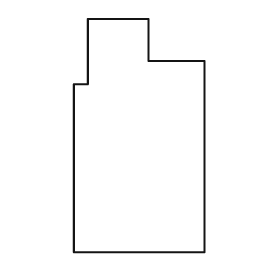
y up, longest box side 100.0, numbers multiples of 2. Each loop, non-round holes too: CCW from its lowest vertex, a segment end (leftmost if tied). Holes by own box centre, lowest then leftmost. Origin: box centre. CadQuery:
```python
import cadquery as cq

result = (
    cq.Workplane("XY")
    .moveTo(-28.0, -50.0)
    .lineTo(28.0, -50.0)
    .lineTo(28.0, 32.0)
    .lineTo(4.0, 32.0)
    .lineTo(4.0, 50.0)
    .lineTo(-22.0, 50.0)
    .lineTo(-22.0, 22.0)
    .lineTo(-28.0, 22.0)
    .close()
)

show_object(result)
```